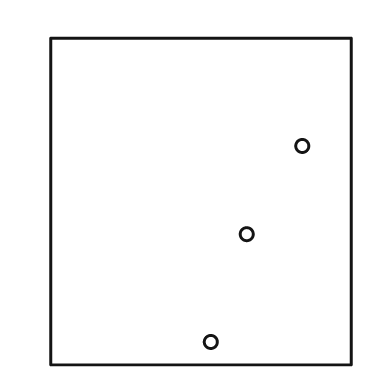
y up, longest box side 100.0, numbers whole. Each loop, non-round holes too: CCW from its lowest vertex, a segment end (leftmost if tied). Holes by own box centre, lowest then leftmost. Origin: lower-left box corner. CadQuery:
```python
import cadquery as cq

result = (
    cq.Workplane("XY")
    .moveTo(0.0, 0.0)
    .lineTo(92.0, 0.0)
    .lineTo(92.0, 100.0)
    .lineTo(0.0, 100.0)
    .close()
    .moveTo(49.0, 7.0)
    .circle(2.0)
    .moveTo(60.0, 40.0)
    .circle(2.0)
    .moveTo(77.0, 67.0)
    .circle(2.0)
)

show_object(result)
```